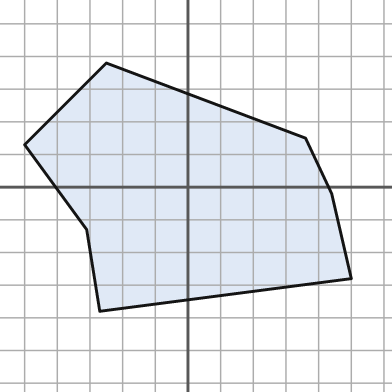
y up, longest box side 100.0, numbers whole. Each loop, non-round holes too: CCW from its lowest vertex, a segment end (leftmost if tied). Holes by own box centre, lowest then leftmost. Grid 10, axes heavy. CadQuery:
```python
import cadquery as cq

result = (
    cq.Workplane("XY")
    .moveTo(-27.0, -38.0)
    .lineTo(50.0, -28.0)
    .lineTo(44.0, -2.0)
    .lineTo(36.0, 15.0)
    .lineTo(-25.0, 38.0)
    .lineTo(-50.0, 13.0)
    .lineTo(-31.0, -13.0)
    .close()
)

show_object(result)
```